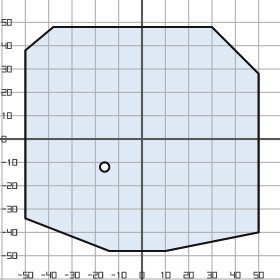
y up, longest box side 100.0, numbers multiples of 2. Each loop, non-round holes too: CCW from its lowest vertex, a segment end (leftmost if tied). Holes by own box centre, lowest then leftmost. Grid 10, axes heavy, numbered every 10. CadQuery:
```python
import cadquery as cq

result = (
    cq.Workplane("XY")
    .moveTo(-14.0, -48.0)
    .lineTo(10.0, -48.0)
    .lineTo(50.0, -40.0)
    .lineTo(50.0, 28.0)
    .lineTo(30.0, 48.0)
    .lineTo(-38.0, 48.0)
    .lineTo(-50.0, 38.0)
    .lineTo(-50.0, -34.0)
    .close()
    .moveTo(-16.0, -12.0)
    .circle(2.0)
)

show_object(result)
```